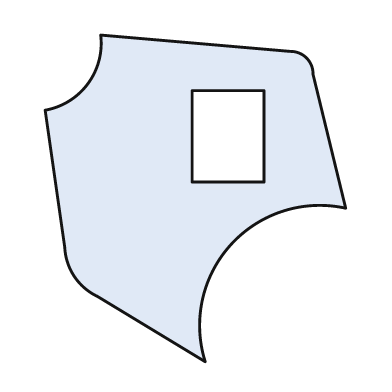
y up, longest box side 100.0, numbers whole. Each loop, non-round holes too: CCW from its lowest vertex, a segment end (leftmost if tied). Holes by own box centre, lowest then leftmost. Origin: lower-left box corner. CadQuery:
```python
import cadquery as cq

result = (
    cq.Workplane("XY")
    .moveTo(49.0, 0.0)
    .threePointArc((57.0, 36.0), (92.0, 47.0))
    .lineTo(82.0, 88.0)
    .threePointArc((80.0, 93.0), (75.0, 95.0))
    .lineTo(17.0, 100.0)
    .threePointArc((13.0, 85.0), (0.0, 77.0))
    .lineTo(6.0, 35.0)
    .threePointArc((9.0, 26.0), (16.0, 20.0))
    .close()
    .moveTo(45.0, 55.0)
    .lineTo(67.0, 55.0)
    .lineTo(67.0, 83.0)
    .lineTo(45.0, 83.0)
    .close()
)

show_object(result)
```